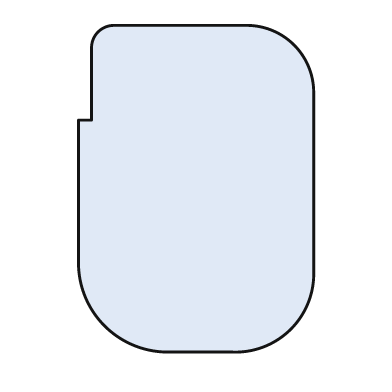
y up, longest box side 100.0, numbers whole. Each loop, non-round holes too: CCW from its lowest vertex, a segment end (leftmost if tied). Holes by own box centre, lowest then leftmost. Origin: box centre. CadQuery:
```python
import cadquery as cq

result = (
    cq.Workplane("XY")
    .moveTo(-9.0, -50.0)
    .lineTo(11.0, -50.0)
    .threePointArc((29.0, -43.0), (36.0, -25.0))
    .lineTo(36.0, 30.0)
    .threePointArc((30.0, 44.0), (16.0, 50.0))
    .lineTo(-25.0, 50.0)
    .threePointArc((-30.0, 48.0), (-32.0, 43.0))
    .lineTo(-32.0, 21.0)
    .lineTo(-36.0, 21.0)
    .lineTo(-36.0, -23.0)
    .threePointArc((-28.0, -42.0), (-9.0, -50.0))
    .close()
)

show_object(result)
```